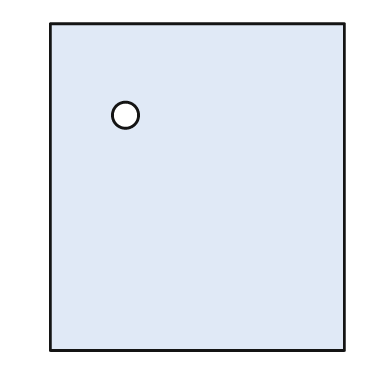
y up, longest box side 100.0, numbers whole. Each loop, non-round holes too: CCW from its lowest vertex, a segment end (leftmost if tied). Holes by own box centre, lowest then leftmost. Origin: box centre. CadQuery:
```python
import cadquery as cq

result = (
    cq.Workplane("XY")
    .moveTo(-45.0, -50.0)
    .lineTo(45.0, -50.0)
    .lineTo(45.0, 50.0)
    .lineTo(-45.0, 50.0)
    .close()
    .moveTo(-22.0, 22.0)
    .circle(4.0)
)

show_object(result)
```